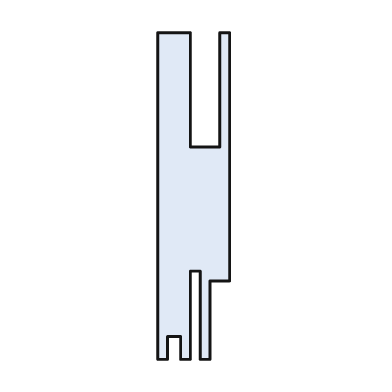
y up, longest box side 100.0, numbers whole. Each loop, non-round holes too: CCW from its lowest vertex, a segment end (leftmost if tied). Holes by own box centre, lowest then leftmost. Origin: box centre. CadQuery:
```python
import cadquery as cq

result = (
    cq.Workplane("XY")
    .moveTo(-11.0, -50.0)
    .lineTo(-8.0, -50.0)
    .lineTo(-8.0, -43.0)
    .lineTo(-4.0, -43.0)
    .lineTo(-4.0, -50.0)
    .lineTo(-1.0, -50.0)
    .lineTo(-1.0, -23.0)
    .lineTo(2.0, -23.0)
    .lineTo(2.0, -50.0)
    .lineTo(5.0, -50.0)
    .lineTo(5.0, -26.0)
    .lineTo(11.0, -26.0)
    .lineTo(11.0, 50.0)
    .lineTo(8.0, 50.0)
    .lineTo(8.0, 15.0)
    .lineTo(-1.0, 15.0)
    .lineTo(-1.0, 50.0)
    .lineTo(-11.0, 50.0)
    .close()
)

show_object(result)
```